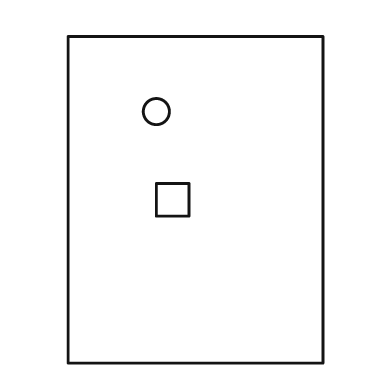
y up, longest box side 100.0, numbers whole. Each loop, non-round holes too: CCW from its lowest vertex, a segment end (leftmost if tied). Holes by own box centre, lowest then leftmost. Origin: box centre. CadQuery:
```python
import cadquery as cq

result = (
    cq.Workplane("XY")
    .moveTo(-39.0, -50.0)
    .lineTo(39.0, -50.0)
    .lineTo(39.0, 50.0)
    .lineTo(-39.0, 50.0)
    .close()
    .moveTo(-12.0, -5.0)
    .lineTo(-2.0, -5.0)
    .lineTo(-2.0, 5.0)
    .lineTo(-12.0, 5.0)
    .close()
    .moveTo(-12.0, 27.0)
    .circle(4.0)
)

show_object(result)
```